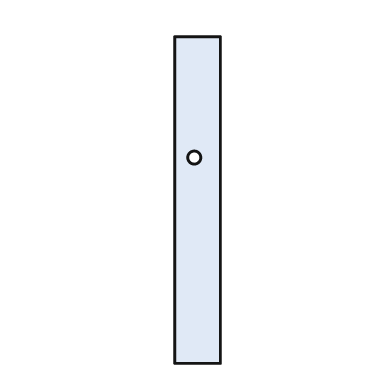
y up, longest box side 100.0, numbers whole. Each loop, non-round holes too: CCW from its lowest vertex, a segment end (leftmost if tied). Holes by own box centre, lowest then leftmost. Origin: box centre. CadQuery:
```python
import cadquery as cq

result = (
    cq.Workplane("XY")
    .moveTo(-7.0, -50.0)
    .lineTo(7.0, -50.0)
    .lineTo(7.0, 50.0)
    .lineTo(-7.0, 50.0)
    .close()
    .moveTo(-1.0, 13.0)
    .circle(2.0)
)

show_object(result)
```